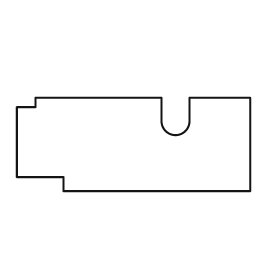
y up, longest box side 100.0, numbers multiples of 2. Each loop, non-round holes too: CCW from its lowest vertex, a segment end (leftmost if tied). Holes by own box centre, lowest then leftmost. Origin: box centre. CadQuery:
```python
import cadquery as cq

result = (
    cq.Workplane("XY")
    .moveTo(-30.0, -20.0)
    .lineTo(50.0, -20.0)
    .lineTo(50.0, 20.0)
    .lineTo(24.0, 20.0)
    .lineTo(24.0, 10.0)
    .threePointArc((18.0, 4.0), (12.0, 10.0))
    .lineTo(12.0, 20.0)
    .lineTo(-42.0, 20.0)
    .lineTo(-42.0, 16.0)
    .lineTo(-50.0, 16.0)
    .lineTo(-50.0, -14.0)
    .lineTo(-30.0, -14.0)
    .close()
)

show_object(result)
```